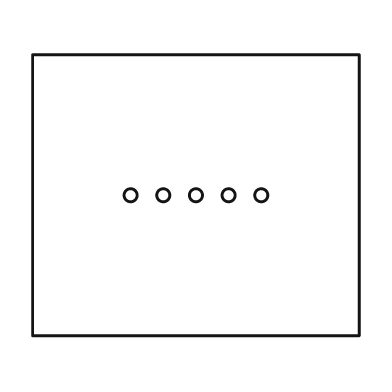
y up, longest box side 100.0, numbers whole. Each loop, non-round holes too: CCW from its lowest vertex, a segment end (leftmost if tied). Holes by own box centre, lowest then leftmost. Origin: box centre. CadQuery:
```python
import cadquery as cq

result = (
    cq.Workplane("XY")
    .moveTo(-50.0, -43.0)
    .lineTo(50.0, -43.0)
    .lineTo(50.0, 43.0)
    .lineTo(-50.0, 43.0)
    .close()
    .moveTo(-20.0, 0.0)
    .circle(2.0)
    .moveTo(-10.0, 0.0)
    .circle(2.0)
    .moveTo(0.0, 0.0)
    .circle(2.0)
    .moveTo(10.0, 0.0)
    .circle(2.0)
    .moveTo(20.0, 0.0)
    .circle(2.0)
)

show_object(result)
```